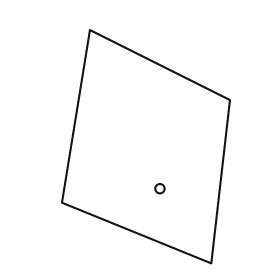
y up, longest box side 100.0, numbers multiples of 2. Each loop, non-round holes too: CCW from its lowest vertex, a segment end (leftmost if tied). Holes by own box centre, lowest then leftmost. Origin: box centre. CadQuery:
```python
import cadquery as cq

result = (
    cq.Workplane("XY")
    .moveTo(28.0, -50.0)
    .lineTo(36.0, 20.0)
    .lineTo(-24.0, 50.0)
    .lineTo(-36.0, -24.0)
    .close()
    .moveTo(6.0, -18.0)
    .circle(2.0)
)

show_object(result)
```